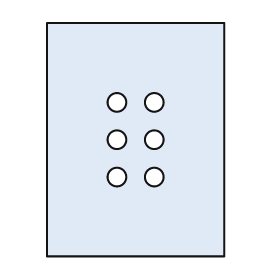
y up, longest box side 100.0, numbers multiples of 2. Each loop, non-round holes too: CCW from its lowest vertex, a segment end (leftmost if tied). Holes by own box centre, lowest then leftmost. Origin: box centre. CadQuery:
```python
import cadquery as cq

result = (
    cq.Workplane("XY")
    .moveTo(-38.0, -50.0)
    .lineTo(38.0, -50.0)
    .lineTo(38.0, 50.0)
    .lineTo(-38.0, 50.0)
    .close()
    .moveTo(-8.0, -16.0)
    .circle(4.0)
    .moveTo(8.0, -16.0)
    .circle(4.0)
    .moveTo(-8.0, 0.0)
    .circle(4.0)
    .moveTo(8.0, 0.0)
    .circle(4.0)
    .moveTo(-8.0, 16.0)
    .circle(4.0)
    .moveTo(8.0, 16.0)
    .circle(4.0)
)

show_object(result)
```